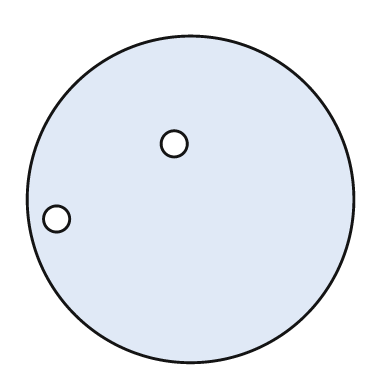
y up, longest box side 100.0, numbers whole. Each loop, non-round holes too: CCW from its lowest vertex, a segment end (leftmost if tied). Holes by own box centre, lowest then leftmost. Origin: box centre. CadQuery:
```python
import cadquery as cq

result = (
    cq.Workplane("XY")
    .moveTo(0.0, 0.0)
    .circle(50.0)
    .moveTo(-41.0, -6.0)
    .circle(4.0)
    .moveTo(-5.0, 17.0)
    .circle(4.0)
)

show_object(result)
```